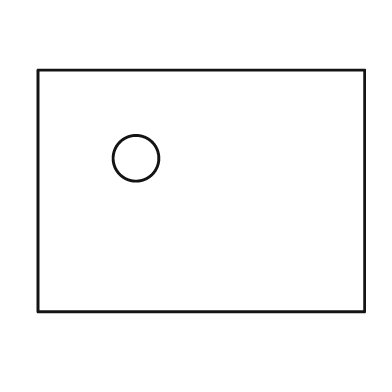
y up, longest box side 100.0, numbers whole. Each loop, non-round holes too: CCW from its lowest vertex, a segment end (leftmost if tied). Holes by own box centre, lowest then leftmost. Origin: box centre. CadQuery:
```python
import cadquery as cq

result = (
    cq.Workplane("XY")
    .moveTo(-50.0, -37.0)
    .lineTo(50.0, -37.0)
    .lineTo(50.0, 37.0)
    .lineTo(-50.0, 37.0)
    .close()
    .moveTo(-20.0, 10.0)
    .circle(7.0)
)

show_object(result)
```